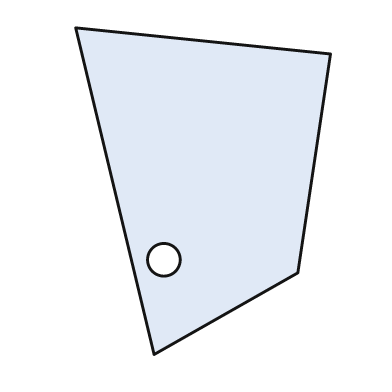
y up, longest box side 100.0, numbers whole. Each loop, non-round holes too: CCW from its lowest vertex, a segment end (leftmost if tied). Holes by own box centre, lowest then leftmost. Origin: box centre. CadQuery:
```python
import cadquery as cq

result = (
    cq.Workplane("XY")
    .moveTo(-15.0, -50.0)
    .lineTo(29.0, -25.0)
    .lineTo(39.0, 42.0)
    .lineTo(-39.0, 50.0)
    .close()
    .moveTo(-12.0, -21.0)
    .circle(5.0)
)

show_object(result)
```